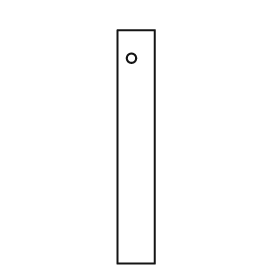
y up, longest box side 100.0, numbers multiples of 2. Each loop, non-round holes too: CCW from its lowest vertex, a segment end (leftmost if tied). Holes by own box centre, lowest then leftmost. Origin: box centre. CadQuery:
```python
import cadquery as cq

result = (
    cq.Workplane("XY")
    .moveTo(-8.0, -50.0)
    .lineTo(8.0, -50.0)
    .lineTo(8.0, 50.0)
    .lineTo(-8.0, 50.0)
    .close()
    .moveTo(-2.0, 38.0)
    .circle(2.0)
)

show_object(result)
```